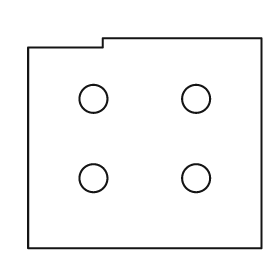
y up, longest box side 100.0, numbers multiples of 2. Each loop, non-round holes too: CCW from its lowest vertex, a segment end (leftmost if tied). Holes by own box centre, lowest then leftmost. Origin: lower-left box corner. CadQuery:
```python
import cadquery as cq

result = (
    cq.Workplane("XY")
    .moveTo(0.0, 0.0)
    .lineTo(100.0, 0.0)
    .lineTo(100.0, 90.0)
    .lineTo(32.0, 90.0)
    .lineTo(32.0, 86.0)
    .lineTo(0.0, 86.0)
    .close()
    .moveTo(28.0, 30.0)
    .circle(6.0)
    .moveTo(72.0, 30.0)
    .circle(6.0)
    .moveTo(28.0, 64.0)
    .circle(6.0)
    .moveTo(72.0, 64.0)
    .circle(6.0)
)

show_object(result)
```